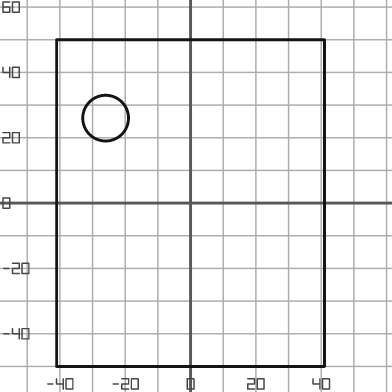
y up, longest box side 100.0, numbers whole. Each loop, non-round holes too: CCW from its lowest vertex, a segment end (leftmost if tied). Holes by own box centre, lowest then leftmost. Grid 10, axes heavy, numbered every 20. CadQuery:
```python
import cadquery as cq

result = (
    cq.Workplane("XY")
    .moveTo(-41.0, -50.0)
    .lineTo(41.0, -50.0)
    .lineTo(41.0, 50.0)
    .lineTo(-41.0, 50.0)
    .close()
    .moveTo(-26.0, 26.0)
    .circle(7.0)
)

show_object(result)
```